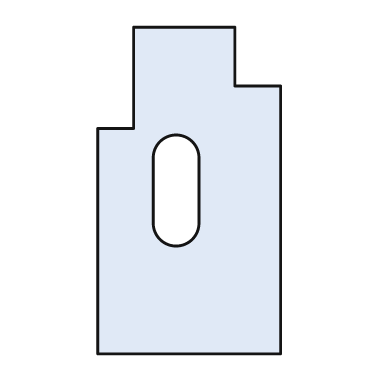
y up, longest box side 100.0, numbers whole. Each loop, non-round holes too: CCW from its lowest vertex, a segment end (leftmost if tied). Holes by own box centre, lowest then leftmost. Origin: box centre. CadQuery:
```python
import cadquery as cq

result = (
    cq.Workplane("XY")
    .moveTo(-28.0, -50.0)
    .lineTo(28.0, -50.0)
    .lineTo(28.0, 32.0)
    .lineTo(14.0, 32.0)
    .lineTo(14.0, 50.0)
    .lineTo(-17.0, 50.0)
    .lineTo(-17.0, 19.0)
    .lineTo(-28.0, 19.0)
    .close()
    .moveTo(-11.0, -10.0)
    .threePointArc((-4.0, -17.0), (3.0, -10.0))
    .lineTo(3.0, 10.0)
    .threePointArc((-4.0, 17.0), (-11.0, 10.0))
    .close()
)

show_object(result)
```